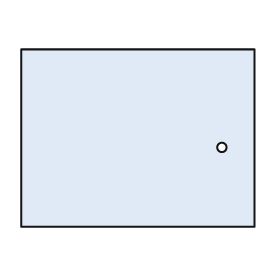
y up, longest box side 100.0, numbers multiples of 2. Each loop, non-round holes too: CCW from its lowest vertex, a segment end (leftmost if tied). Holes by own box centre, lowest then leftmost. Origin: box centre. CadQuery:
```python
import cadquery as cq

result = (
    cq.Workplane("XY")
    .moveTo(-50.0, -38.0)
    .lineTo(50.0, -38.0)
    .lineTo(50.0, 38.0)
    .lineTo(-50.0, 38.0)
    .close()
    .moveTo(36.0, -4.0)
    .circle(2.0)
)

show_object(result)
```